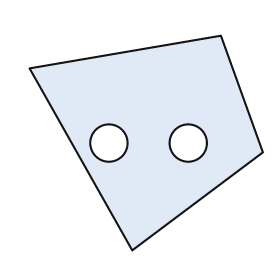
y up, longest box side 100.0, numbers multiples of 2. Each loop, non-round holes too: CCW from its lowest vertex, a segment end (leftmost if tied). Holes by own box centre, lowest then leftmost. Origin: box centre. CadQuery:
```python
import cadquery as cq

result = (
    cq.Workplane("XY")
    .moveTo(-6.0, -46.0)
    .lineTo(50.0, -4.0)
    .lineTo(32.0, 46.0)
    .lineTo(-50.0, 32.0)
    .close()
    .moveTo(-16.0, 0.0)
    .circle(8.0)
    .moveTo(18.0, 0.0)
    .circle(8.0)
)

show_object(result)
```